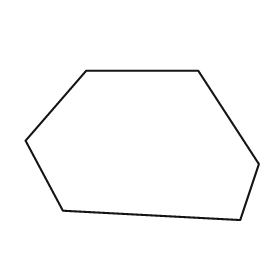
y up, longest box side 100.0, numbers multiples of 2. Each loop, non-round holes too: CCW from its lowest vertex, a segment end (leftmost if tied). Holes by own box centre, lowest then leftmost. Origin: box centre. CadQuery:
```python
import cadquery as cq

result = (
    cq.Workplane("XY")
    .moveTo(42.0, -32.0)
    .lineTo(50.0, -8.0)
    .lineTo(24.0, 32.0)
    .lineTo(-24.0, 32.0)
    .lineTo(-50.0, 2.0)
    .lineTo(-34.0, -28.0)
    .close()
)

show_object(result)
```